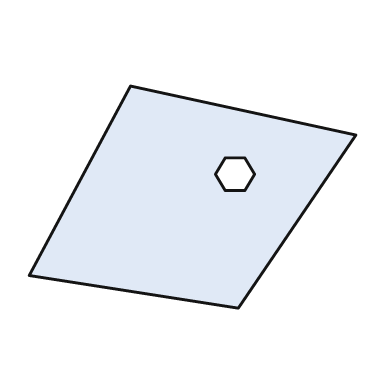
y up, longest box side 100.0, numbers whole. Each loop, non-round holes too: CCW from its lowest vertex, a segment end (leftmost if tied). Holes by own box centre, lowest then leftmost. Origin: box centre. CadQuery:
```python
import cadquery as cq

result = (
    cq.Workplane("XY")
    .moveTo(14.0, -34.0)
    .lineTo(50.0, 19.0)
    .lineTo(-19.0, 34.0)
    .lineTo(-50.0, -24.0)
    .close()
    .moveTo(10.0, 2.0)
    .lineTo(16.0, 2.0)
    .lineTo(19.0, 7.0)
    .lineTo(16.0, 12.0)
    .lineTo(10.0, 12.0)
    .lineTo(7.0, 7.0)
    .close()
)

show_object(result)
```